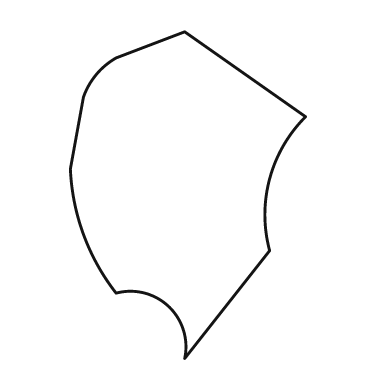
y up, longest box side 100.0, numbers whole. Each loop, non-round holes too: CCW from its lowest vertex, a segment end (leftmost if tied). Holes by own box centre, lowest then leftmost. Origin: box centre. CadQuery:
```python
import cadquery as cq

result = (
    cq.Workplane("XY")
    .moveTo(-1.0, -50.0)
    .lineTo(25.0, -17.0)
    .threePointArc((25.0, 5.0), (36.0, 24.0))
    .lineTo(-1.0, 50.0)
    .lineTo(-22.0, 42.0)
    .threePointArc((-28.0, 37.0), (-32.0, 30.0))
    .lineTo(-36.0, 8.0)
    .threePointArc((-32.0, -12.0), (-22.0, -30.0))
    .threePointArc((-6.0, -34.0), (-1.0, -50.0))
    .close()
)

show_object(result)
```